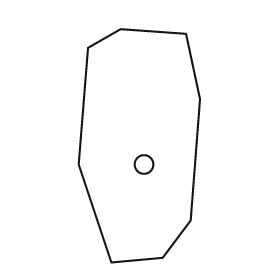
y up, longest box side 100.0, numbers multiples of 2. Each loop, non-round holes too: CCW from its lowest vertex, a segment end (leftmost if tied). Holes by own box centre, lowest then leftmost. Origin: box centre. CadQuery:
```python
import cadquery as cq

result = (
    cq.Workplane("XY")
    .moveTo(-12.0, -50.0)
    .lineTo(10.0, -48.0)
    .lineTo(22.0, -32.0)
    .lineTo(26.0, 20.0)
    .lineTo(20.0, 48.0)
    .lineTo(-8.0, 50.0)
    .lineTo(-22.0, 42.0)
    .lineTo(-26.0, -8.0)
    .close()
    .moveTo(2.0, -8.0)
    .circle(4.0)
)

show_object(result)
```